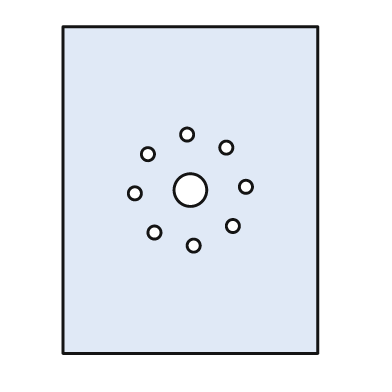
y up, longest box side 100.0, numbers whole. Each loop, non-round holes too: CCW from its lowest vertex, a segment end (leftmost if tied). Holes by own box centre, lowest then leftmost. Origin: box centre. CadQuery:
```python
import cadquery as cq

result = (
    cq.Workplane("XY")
    .moveTo(-39.0, -50.0)
    .lineTo(39.0, -50.0)
    .lineTo(39.0, 50.0)
    .lineTo(-39.0, 50.0)
    .close()
    .moveTo(1.0, -17.0)
    .circle(2.0)
    .moveTo(-11.0, -13.0)
    .circle(2.0)
    .moveTo(13.0, -11.0)
    .circle(2.0)
    .moveTo(-17.0, -1.0)
    .circle(2.0)
    .moveTo(0.0, 0.0)
    .circle(5.0)
    .moveTo(17.0, 1.0)
    .circle(2.0)
    .moveTo(-13.0, 11.0)
    .circle(2.0)
    .moveTo(11.0, 13.0)
    .circle(2.0)
    .moveTo(-1.0, 17.0)
    .circle(2.0)
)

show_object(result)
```